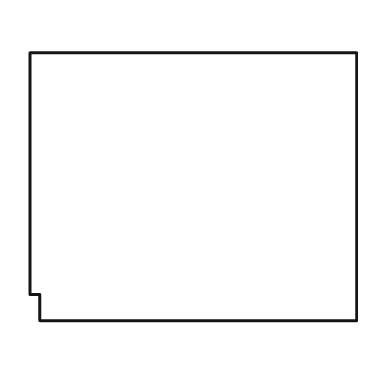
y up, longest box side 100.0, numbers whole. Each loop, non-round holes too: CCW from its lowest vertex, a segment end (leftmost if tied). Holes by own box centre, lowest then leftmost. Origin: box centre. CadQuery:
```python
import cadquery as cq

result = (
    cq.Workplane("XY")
    .moveTo(-47.0, -41.0)
    .lineTo(50.0, -41.0)
    .lineTo(50.0, 41.0)
    .lineTo(-50.0, 41.0)
    .lineTo(-50.0, -33.0)
    .lineTo(-47.0, -33.0)
    .close()
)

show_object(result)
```